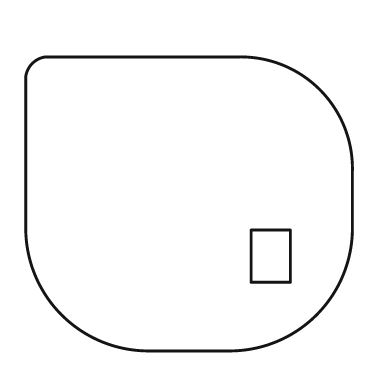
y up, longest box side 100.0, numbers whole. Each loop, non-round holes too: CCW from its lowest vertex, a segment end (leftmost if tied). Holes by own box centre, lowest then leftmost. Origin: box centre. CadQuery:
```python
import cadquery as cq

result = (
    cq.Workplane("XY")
    .moveTo(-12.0, -45.0)
    .lineTo(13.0, -45.0)
    .threePointArc((39.0, -34.0), (50.0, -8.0))
    .lineTo(50.0, 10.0)
    .threePointArc((40.0, 35.0), (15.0, 45.0))
    .lineTo(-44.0, 45.0)
    .threePointArc((-48.0, 43.0), (-50.0, 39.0))
    .lineTo(-50.0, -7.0)
    .threePointArc((-39.0, -34.0), (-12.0, -45.0))
    .close()
    .moveTo(19.0, -24.0)
    .lineTo(31.0, -24.0)
    .lineTo(31.0, -8.0)
    .lineTo(19.0, -8.0)
    .close()
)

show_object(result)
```